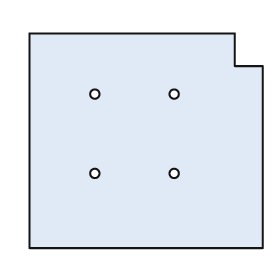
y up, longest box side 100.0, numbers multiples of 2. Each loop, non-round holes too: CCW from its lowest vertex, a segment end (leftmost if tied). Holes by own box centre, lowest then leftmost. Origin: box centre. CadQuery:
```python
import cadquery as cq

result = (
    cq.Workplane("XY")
    .moveTo(-50.0, -46.0)
    .lineTo(50.0, -46.0)
    .lineTo(50.0, 32.0)
    .lineTo(38.0, 32.0)
    .lineTo(38.0, 46.0)
    .lineTo(-50.0, 46.0)
    .close()
    .moveTo(-22.0, -14.0)
    .circle(2.0)
    .moveTo(12.0, -14.0)
    .circle(2.0)
    .moveTo(-22.0, 20.0)
    .circle(2.0)
    .moveTo(12.0, 20.0)
    .circle(2.0)
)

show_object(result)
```